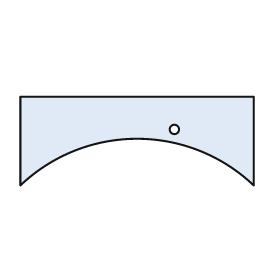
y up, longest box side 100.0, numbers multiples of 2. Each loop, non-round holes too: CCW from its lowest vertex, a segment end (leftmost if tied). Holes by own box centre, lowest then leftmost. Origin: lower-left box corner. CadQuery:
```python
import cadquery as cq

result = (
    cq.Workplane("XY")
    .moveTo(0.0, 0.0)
    .threePointArc((50.0, 20.0), (100.0, 0.0))
    .lineTo(100.0, 38.0)
    .lineTo(0.0, 38.0)
    .close()
    .moveTo(66.0, 24.0)
    .circle(2.0)
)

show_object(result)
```